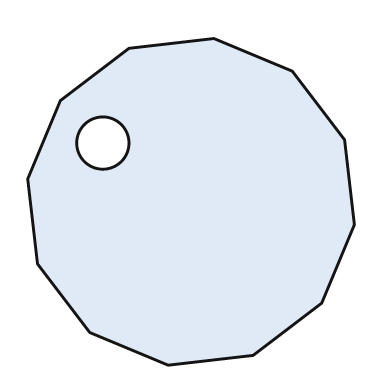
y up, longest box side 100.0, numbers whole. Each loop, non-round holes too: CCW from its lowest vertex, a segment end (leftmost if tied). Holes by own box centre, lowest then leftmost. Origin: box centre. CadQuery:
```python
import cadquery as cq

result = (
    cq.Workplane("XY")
    .moveTo(-7.0, -50.0)
    .lineTo(19.0, -47.0)
    .lineTo(40.0, -31.0)
    .lineTo(50.0, -7.0)
    .lineTo(47.0, 19.0)
    .lineTo(31.0, 40.0)
    .lineTo(7.0, 50.0)
    .lineTo(-19.0, 47.0)
    .lineTo(-40.0, 31.0)
    .lineTo(-50.0, 7.0)
    .lineTo(-47.0, -19.0)
    .lineTo(-31.0, -40.0)
    .close()
    .moveTo(-27.0, 18.0)
    .circle(8.0)
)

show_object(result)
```